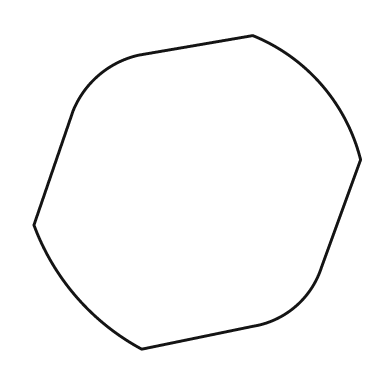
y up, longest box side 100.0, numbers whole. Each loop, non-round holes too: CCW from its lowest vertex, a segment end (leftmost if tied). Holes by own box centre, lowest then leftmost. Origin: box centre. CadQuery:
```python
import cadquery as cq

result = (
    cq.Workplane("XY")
    .moveTo(-17.0, -48.0)
    .lineTo(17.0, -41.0)
    .threePointArc((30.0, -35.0), (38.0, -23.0))
    .lineTo(50.0, 10.0)
    .threePointArc((38.0, 33.0), (17.0, 48.0))
    .lineTo(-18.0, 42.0)
    .threePointArc((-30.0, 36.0), (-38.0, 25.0))
    .lineTo(-50.0, -10.0)
    .threePointArc((-37.0, -32.0), (-17.0, -48.0))
    .close()
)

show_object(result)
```